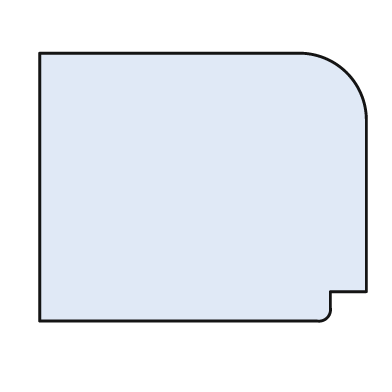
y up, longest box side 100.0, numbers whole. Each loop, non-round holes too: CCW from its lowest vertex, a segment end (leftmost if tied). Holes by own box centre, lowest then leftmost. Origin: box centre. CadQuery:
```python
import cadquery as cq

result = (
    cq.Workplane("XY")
    .moveTo(-50.0, -41.0)
    .lineTo(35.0, -41.0)
    .threePointArc((38.0, -40.0), (39.0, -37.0))
    .lineTo(39.0, -32.0)
    .lineTo(50.0, -32.0)
    .lineTo(50.0, 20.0)
    .threePointArc((44.0, 35.0), (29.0, 41.0))
    .lineTo(-50.0, 41.0)
    .close()
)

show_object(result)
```